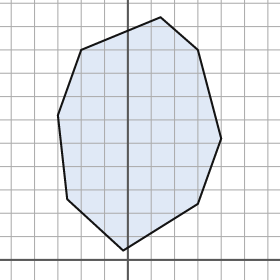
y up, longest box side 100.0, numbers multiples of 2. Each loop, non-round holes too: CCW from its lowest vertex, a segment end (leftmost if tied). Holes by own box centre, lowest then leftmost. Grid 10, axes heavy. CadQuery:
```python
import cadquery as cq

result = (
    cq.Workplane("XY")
    .moveTo(-2.0, 4.0)
    .lineTo(30.0, 24.0)
    .lineTo(40.0, 52.0)
    .lineTo(30.0, 90.0)
    .lineTo(14.0, 104.0)
    .lineTo(-20.0, 90.0)
    .lineTo(-30.0, 62.0)
    .lineTo(-26.0, 26.0)
    .close()
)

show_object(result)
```